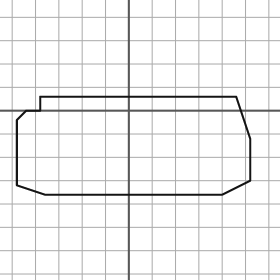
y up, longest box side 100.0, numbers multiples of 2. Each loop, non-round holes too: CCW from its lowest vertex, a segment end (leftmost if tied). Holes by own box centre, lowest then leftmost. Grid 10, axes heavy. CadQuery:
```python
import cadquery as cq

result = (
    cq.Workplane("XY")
    .moveTo(-36.0, -36.0)
    .lineTo(40.0, -36.0)
    .lineTo(52.0, -30.0)
    .lineTo(52.0, -12.0)
    .lineTo(46.0, 6.0)
    .lineTo(-38.0, 6.0)
    .lineTo(-38.0, 0.0)
    .lineTo(-44.0, 0.0)
    .lineTo(-48.0, -4.0)
    .lineTo(-48.0, -32.0)
    .close()
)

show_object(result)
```